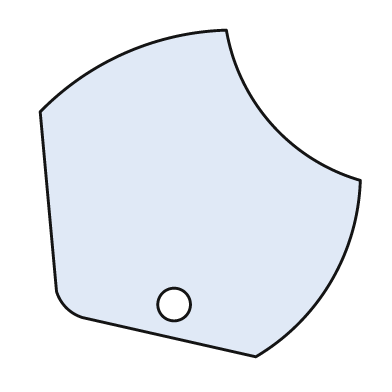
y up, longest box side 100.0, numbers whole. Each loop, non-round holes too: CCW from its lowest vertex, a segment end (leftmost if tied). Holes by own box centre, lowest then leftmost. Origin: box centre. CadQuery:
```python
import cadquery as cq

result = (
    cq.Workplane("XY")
    .moveTo(17.0, -50.0)
    .threePointArc((40.0, -27.0), (49.0, 4.0))
    .threePointArc((22.0, 21.0), (8.0, 50.0))
    .threePointArc((-23.0, 43.0), (-49.0, 25.0))
    .lineTo(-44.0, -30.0)
    .threePointArc((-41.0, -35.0), (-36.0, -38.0))
    .close()
    .moveTo(-8.0, -34.0)
    .circle(5.0)
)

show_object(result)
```